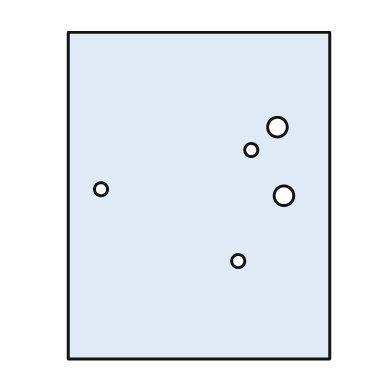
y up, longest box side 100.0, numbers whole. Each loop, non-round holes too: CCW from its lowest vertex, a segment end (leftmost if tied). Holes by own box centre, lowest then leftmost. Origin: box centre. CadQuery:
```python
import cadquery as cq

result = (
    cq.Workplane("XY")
    .moveTo(-40.0, -50.0)
    .lineTo(40.0, -50.0)
    .lineTo(40.0, 50.0)
    .lineTo(-40.0, 50.0)
    .close()
    .moveTo(12.0, -20.0)
    .circle(2.0)
    .moveTo(26.0, 0.0)
    .circle(3.0)
    .moveTo(-30.0, 2.0)
    .circle(2.0)
    .moveTo(16.0, 14.0)
    .circle(2.0)
    .moveTo(24.0, 21.0)
    .circle(3.0)
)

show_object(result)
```